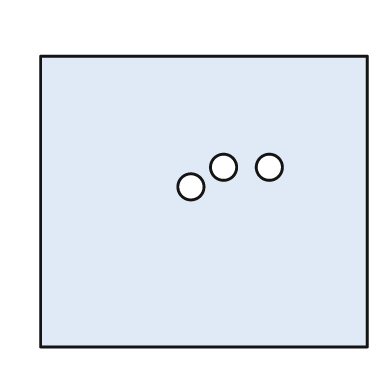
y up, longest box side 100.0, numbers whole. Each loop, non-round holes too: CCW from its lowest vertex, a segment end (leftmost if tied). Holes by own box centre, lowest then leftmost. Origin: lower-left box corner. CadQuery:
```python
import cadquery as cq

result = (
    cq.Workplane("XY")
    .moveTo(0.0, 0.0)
    .lineTo(100.0, 0.0)
    .lineTo(100.0, 89.0)
    .lineTo(0.0, 89.0)
    .close()
    .moveTo(46.0, 49.0)
    .circle(4.0)
    .moveTo(56.0, 55.0)
    .circle(4.0)
    .moveTo(70.0, 55.0)
    .circle(4.0)
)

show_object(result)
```